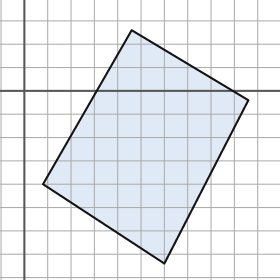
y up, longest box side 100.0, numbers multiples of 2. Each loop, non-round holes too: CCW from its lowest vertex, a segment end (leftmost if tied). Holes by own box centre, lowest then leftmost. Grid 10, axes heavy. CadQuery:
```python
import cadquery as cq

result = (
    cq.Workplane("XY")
    .moveTo(60.0, -74.0)
    .lineTo(96.0, -4.0)
    .lineTo(46.0, 26.0)
    .lineTo(8.0, -40.0)
    .close()
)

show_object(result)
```